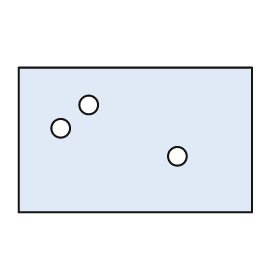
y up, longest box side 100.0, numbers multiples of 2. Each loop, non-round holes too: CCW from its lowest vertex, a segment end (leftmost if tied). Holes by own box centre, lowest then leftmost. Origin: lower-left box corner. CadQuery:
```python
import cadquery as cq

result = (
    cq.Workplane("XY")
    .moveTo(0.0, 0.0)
    .lineTo(100.0, 0.0)
    .lineTo(100.0, 62.0)
    .lineTo(0.0, 62.0)
    .close()
    .moveTo(68.0, 24.0)
    .circle(4.0)
    .moveTo(18.0, 36.0)
    .circle(4.0)
    .moveTo(30.0, 46.0)
    .circle(4.0)
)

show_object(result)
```